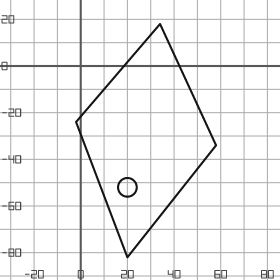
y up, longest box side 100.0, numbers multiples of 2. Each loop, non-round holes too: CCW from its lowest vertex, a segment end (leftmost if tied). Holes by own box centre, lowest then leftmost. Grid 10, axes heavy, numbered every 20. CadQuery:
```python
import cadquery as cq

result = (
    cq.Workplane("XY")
    .moveTo(20.0, -82.0)
    .lineTo(58.0, -34.0)
    .lineTo(34.0, 18.0)
    .lineTo(-2.0, -24.0)
    .close()
    .moveTo(20.0, -52.0)
    .circle(4.0)
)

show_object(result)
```